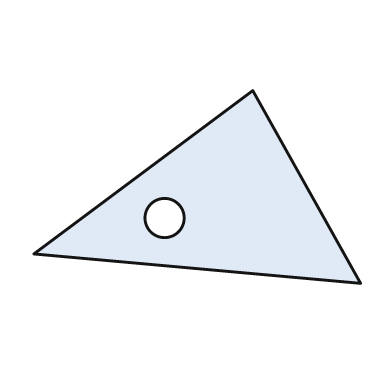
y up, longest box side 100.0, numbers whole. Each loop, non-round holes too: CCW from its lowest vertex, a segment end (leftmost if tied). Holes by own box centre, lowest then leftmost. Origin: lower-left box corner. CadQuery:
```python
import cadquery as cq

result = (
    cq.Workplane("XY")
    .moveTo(100.0, 0.0)
    .lineTo(67.0, 59.0)
    .lineTo(0.0, 9.0)
    .close()
    .moveTo(40.0, 20.0)
    .circle(6.0)
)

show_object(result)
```